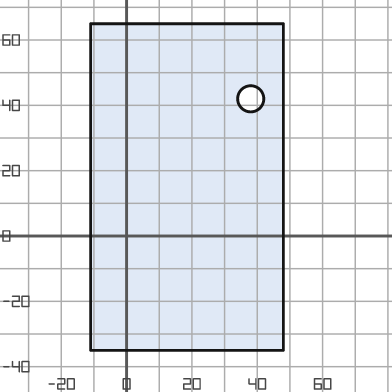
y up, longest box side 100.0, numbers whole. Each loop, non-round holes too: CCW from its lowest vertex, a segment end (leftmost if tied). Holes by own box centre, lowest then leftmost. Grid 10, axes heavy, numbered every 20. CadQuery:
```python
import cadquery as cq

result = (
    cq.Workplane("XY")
    .moveTo(-11.0, -35.0)
    .lineTo(48.0, -35.0)
    .lineTo(48.0, 65.0)
    .lineTo(-11.0, 65.0)
    .close()
    .moveTo(38.0, 42.0)
    .circle(4.0)
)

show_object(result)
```